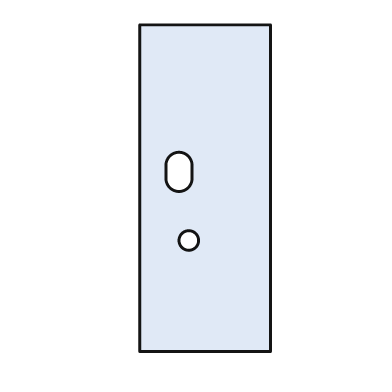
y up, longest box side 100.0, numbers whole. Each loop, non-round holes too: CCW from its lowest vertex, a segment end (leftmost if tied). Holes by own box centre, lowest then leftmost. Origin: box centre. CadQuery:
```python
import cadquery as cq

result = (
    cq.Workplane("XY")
    .moveTo(-20.0, -50.0)
    .lineTo(20.0, -50.0)
    .lineTo(20.0, 50.0)
    .lineTo(-20.0, 50.0)
    .close()
    .moveTo(-5.0, -16.0)
    .circle(3.0)
    .moveTo(-12.0, 3.0)
    .threePointArc((-8.0, -1.0), (-4.0, 3.0))
    .lineTo(-4.0, 7.0)
    .threePointArc((-8.0, 11.0), (-12.0, 7.0))
    .close()
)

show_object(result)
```